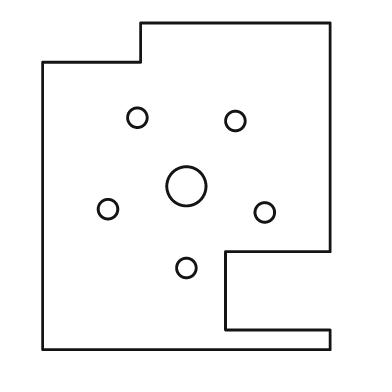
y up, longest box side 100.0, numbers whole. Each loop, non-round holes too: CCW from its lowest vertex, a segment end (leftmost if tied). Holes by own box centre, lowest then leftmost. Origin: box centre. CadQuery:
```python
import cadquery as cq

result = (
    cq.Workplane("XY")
    .moveTo(-44.0, -50.0)
    .lineTo(44.0, -50.0)
    .lineTo(44.0, -44.0)
    .lineTo(12.0, -44.0)
    .lineTo(12.0, -20.0)
    .lineTo(44.0, -20.0)
    .lineTo(44.0, 50.0)
    .lineTo(-14.0, 50.0)
    .lineTo(-14.0, 38.0)
    .lineTo(-44.0, 38.0)
    .close()
    .moveTo(0.0, -25.0)
    .circle(3.0)
    .moveTo(24.0, -8.0)
    .circle(3.0)
    .moveTo(-24.0, -7.0)
    .circle(3.0)
    .moveTo(0.0, 0.0)
    .circle(6.0)
    .moveTo(15.0, 20.0)
    .circle(3.0)
    .moveTo(-15.0, 21.0)
    .circle(3.0)
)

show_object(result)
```